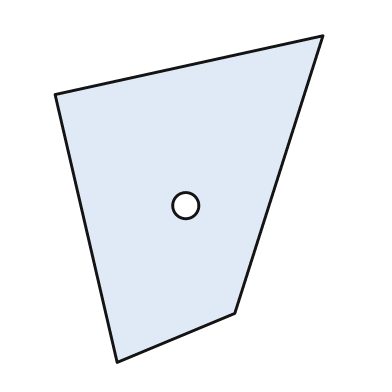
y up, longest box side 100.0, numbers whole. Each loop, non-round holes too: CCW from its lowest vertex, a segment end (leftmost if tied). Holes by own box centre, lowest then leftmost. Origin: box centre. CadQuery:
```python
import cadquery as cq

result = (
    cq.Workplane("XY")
    .moveTo(-22.0, -50.0)
    .lineTo(14.0, -35.0)
    .lineTo(41.0, 50.0)
    .lineTo(-41.0, 32.0)
    .close()
    .moveTo(-1.0, -2.0)
    .circle(4.0)
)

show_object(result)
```